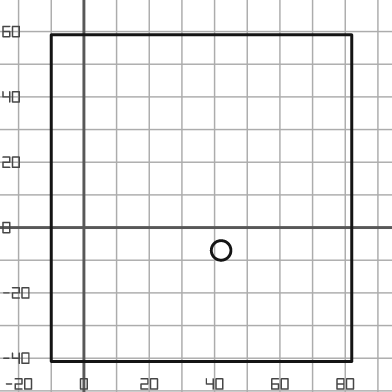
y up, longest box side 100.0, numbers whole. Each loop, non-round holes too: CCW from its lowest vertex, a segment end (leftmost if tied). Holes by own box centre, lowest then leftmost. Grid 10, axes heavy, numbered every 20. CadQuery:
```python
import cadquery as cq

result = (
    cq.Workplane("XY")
    .moveTo(-10.0, -41.0)
    .lineTo(82.0, -41.0)
    .lineTo(82.0, 59.0)
    .lineTo(-10.0, 59.0)
    .close()
    .moveTo(42.0, -7.0)
    .circle(3.0)
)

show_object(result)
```